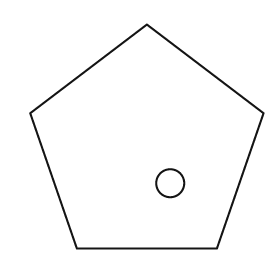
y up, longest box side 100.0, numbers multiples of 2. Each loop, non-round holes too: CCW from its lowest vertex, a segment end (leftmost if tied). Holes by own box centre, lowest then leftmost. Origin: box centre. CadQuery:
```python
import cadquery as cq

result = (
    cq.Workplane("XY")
    .moveTo(-30.0, -48.0)
    .lineTo(30.0, -48.0)
    .lineTo(50.0, 10.0)
    .lineTo(0.0, 48.0)
    .lineTo(-50.0, 10.0)
    .close()
    .moveTo(10.0, -20.0)
    .circle(6.0)
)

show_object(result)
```